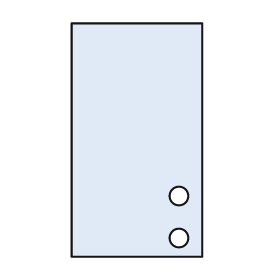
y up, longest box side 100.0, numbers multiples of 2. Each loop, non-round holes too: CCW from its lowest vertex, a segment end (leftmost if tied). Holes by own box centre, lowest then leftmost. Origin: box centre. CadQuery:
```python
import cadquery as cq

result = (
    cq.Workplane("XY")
    .moveTo(-28.0, -50.0)
    .lineTo(28.0, -50.0)
    .lineTo(28.0, 50.0)
    .lineTo(-28.0, 50.0)
    .close()
    .moveTo(18.0, -42.0)
    .circle(4.0)
    .moveTo(18.0, -24.0)
    .circle(4.0)
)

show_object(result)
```